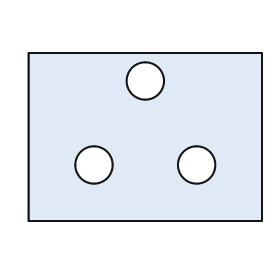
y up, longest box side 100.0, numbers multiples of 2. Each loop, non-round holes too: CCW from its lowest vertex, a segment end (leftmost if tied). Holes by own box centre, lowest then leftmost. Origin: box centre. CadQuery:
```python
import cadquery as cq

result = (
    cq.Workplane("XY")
    .moveTo(-50.0, -36.0)
    .lineTo(50.0, -36.0)
    .lineTo(50.0, 36.0)
    .lineTo(-50.0, 36.0)
    .close()
    .moveTo(-22.0, -12.0)
    .circle(8.0)
    .moveTo(22.0, -12.0)
    .circle(8.0)
    .moveTo(0.0, 24.0)
    .circle(8.0)
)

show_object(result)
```